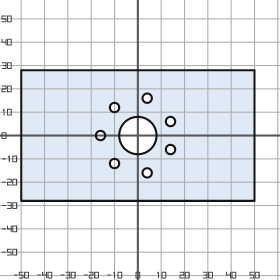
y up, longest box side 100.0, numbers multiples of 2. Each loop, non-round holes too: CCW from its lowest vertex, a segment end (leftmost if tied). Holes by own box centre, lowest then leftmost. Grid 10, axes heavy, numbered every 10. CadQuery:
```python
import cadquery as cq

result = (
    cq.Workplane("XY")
    .moveTo(-50.0, -28.0)
    .lineTo(50.0, -28.0)
    .lineTo(50.0, 28.0)
    .lineTo(-50.0, 28.0)
    .close()
    .moveTo(4.0, -16.0)
    .circle(2.0)
    .moveTo(-10.0, -12.0)
    .circle(2.0)
    .moveTo(14.0, -6.0)
    .circle(2.0)
    .moveTo(-16.0, 0.0)
    .circle(2.0)
    .moveTo(0.0, 0.0)
    .circle(8.0)
    .moveTo(14.0, 6.0)
    .circle(2.0)
    .moveTo(-10.0, 12.0)
    .circle(2.0)
    .moveTo(4.0, 16.0)
    .circle(2.0)
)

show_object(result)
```